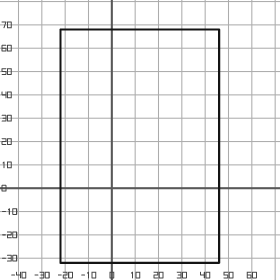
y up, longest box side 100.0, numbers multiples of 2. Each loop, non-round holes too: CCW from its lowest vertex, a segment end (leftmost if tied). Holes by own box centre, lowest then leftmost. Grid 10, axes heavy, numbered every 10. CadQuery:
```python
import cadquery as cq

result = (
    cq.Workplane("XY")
    .moveTo(-22.0, -32.0)
    .lineTo(46.0, -32.0)
    .lineTo(46.0, 68.0)
    .lineTo(-22.0, 68.0)
    .close()
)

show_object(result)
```